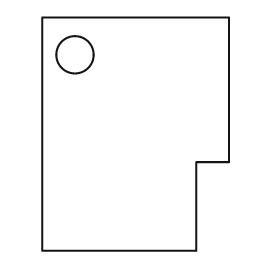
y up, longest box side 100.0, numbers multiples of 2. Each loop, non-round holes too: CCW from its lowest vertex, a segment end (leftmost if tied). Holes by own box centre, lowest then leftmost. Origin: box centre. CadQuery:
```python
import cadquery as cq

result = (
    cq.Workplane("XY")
    .moveTo(-40.0, -50.0)
    .lineTo(26.0, -50.0)
    .lineTo(26.0, -12.0)
    .lineTo(40.0, -12.0)
    .lineTo(40.0, 50.0)
    .lineTo(-40.0, 50.0)
    .close()
    .moveTo(-26.0, 34.0)
    .circle(8.0)
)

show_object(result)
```